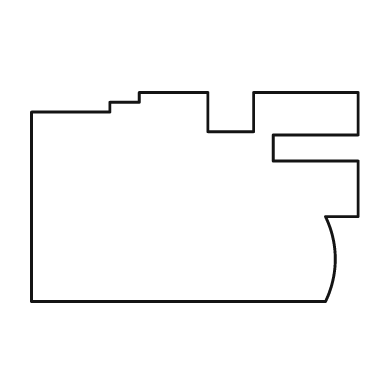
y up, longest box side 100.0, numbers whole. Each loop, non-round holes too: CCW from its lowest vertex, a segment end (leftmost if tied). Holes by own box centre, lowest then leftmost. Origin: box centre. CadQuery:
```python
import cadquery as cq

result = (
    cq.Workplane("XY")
    .moveTo(-50.0, -32.0)
    .lineTo(40.0, -32.0)
    .threePointArc((43.0, -19.0), (40.0, -6.0))
    .lineTo(50.0, -6.0)
    .lineTo(50.0, 11.0)
    .lineTo(24.0, 11.0)
    .lineTo(24.0, 19.0)
    .lineTo(50.0, 19.0)
    .lineTo(50.0, 32.0)
    .lineTo(18.0, 32.0)
    .lineTo(18.0, 20.0)
    .lineTo(4.0, 20.0)
    .lineTo(4.0, 32.0)
    .lineTo(-17.0, 32.0)
    .lineTo(-17.0, 29.0)
    .lineTo(-26.0, 29.0)
    .lineTo(-26.0, 26.0)
    .lineTo(-50.0, 26.0)
    .close()
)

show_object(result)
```